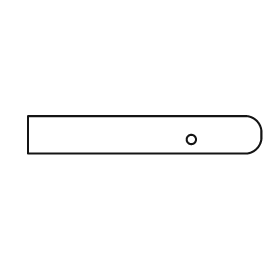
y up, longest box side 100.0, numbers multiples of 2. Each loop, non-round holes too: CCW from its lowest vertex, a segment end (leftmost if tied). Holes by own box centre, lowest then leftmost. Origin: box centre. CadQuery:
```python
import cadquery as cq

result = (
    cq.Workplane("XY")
    .moveTo(-50.0, -8.0)
    .lineTo(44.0, -8.0)
    .threePointArc((48.0, -6.0), (50.0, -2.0))
    .lineTo(50.0, 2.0)
    .threePointArc((48.0, 6.0), (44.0, 8.0))
    .lineTo(-50.0, 8.0)
    .close()
    .moveTo(20.0, -2.0)
    .circle(2.0)
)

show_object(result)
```